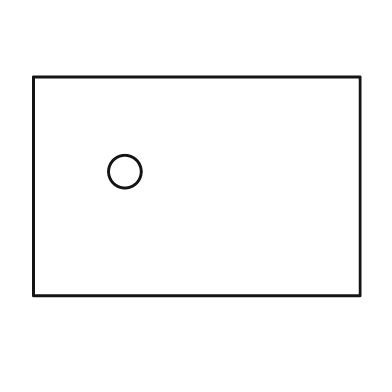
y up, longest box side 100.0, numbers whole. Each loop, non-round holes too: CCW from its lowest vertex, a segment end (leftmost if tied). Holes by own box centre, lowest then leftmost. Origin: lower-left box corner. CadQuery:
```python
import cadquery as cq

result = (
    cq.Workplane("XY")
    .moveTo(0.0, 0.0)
    .lineTo(100.0, 0.0)
    .lineTo(100.0, 67.0)
    .lineTo(0.0, 67.0)
    .close()
    .moveTo(28.0, 38.0)
    .circle(5.0)
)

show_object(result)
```